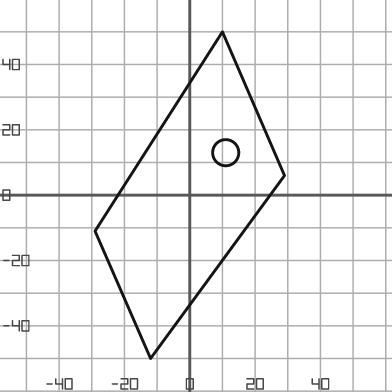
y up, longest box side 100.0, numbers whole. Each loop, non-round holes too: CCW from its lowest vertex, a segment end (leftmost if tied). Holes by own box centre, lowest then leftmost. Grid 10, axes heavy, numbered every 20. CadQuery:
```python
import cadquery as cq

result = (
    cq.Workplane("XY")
    .moveTo(-12.0, -50.0)
    .lineTo(29.0, 6.0)
    .lineTo(10.0, 50.0)
    .lineTo(-29.0, -11.0)
    .close()
    .moveTo(11.0, 13.0)
    .circle(4.0)
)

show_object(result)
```